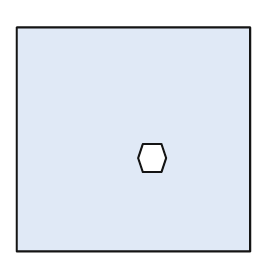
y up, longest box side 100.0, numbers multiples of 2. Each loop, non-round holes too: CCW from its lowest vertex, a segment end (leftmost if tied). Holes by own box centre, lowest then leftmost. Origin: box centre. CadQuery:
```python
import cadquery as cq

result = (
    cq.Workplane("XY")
    .moveTo(-50.0, -48.0)
    .lineTo(50.0, -48.0)
    .lineTo(50.0, 48.0)
    .lineTo(-50.0, 48.0)
    .close()
    .moveTo(4.0, -14.0)
    .lineTo(12.0, -14.0)
    .lineTo(14.0, -8.0)
    .lineTo(12.0, -2.0)
    .lineTo(4.0, -2.0)
    .lineTo(2.0, -8.0)
    .close()
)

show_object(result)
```